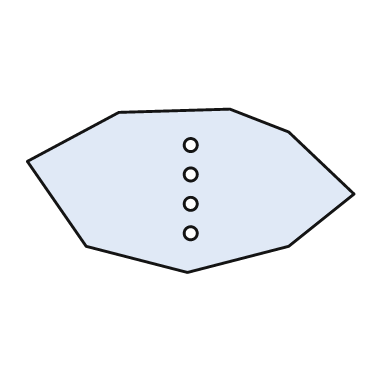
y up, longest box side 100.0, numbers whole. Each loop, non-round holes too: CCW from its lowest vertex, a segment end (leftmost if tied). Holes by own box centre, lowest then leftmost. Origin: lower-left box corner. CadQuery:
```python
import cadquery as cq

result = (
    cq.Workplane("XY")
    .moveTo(49.0, 0.0)
    .lineTo(80.0, 8.0)
    .lineTo(100.0, 24.0)
    .lineTo(80.0, 43.0)
    .lineTo(62.0, 50.0)
    .lineTo(28.0, 49.0)
    .lineTo(0.0, 34.0)
    .lineTo(18.0, 8.0)
    .close()
    .moveTo(50.0, 12.0)
    .circle(2.0)
    .moveTo(50.0, 21.0)
    .circle(2.0)
    .moveTo(50.0, 30.0)
    .circle(2.0)
    .moveTo(50.0, 39.0)
    .circle(2.0)
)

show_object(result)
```